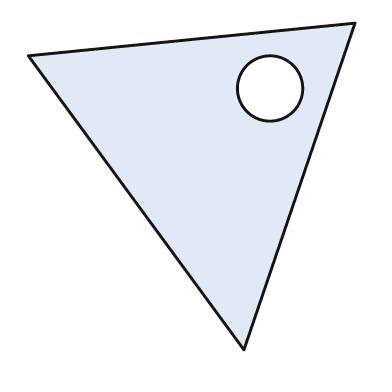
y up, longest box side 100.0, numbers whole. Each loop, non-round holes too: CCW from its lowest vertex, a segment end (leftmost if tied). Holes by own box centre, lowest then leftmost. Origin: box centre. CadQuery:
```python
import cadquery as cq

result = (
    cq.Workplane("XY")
    .moveTo(16.0, -50.0)
    .lineTo(50.0, 50.0)
    .lineTo(-50.0, 40.0)
    .close()
    .moveTo(24.0, 30.0)
    .circle(10.0)
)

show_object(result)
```